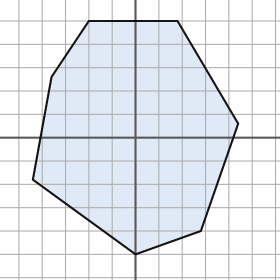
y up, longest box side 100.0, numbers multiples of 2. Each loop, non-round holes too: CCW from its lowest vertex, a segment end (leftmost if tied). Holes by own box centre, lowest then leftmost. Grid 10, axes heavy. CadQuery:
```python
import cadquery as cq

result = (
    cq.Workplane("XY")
    .moveTo(0.0, -50.0)
    .lineTo(28.0, -40.0)
    .lineTo(44.0, 6.0)
    .lineTo(18.0, 50.0)
    .lineTo(-20.0, 50.0)
    .lineTo(-36.0, 26.0)
    .lineTo(-44.0, -18.0)
    .close()
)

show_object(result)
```